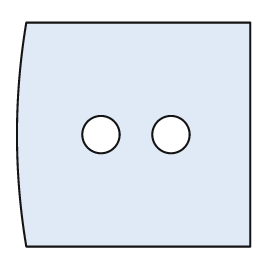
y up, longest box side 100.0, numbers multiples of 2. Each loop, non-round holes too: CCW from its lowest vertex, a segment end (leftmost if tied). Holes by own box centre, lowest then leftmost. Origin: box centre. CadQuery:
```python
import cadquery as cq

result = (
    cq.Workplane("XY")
    .moveTo(-46.0, -48.0)
    .lineTo(50.0, -48.0)
    .lineTo(50.0, 48.0)
    .lineTo(-46.0, 48.0)
    .threePointArc((-50.0, 0.0), (-46.0, -48.0))
    .close()
    .moveTo(-14.0, 0.0)
    .circle(8.0)
    .moveTo(16.0, 0.0)
    .circle(8.0)
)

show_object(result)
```